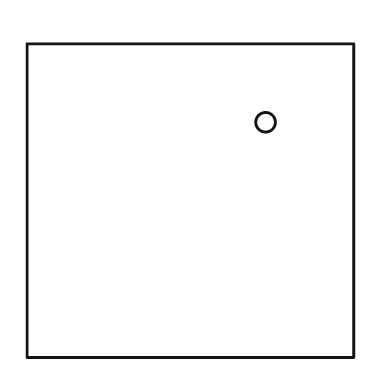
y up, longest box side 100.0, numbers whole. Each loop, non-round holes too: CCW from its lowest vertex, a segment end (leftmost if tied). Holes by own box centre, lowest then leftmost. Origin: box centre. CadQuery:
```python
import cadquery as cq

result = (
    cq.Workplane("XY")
    .moveTo(-50.0, -48.0)
    .lineTo(50.0, -48.0)
    .lineTo(50.0, 48.0)
    .lineTo(-50.0, 48.0)
    .close()
    .moveTo(23.0, 24.0)
    .circle(3.0)
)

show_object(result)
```